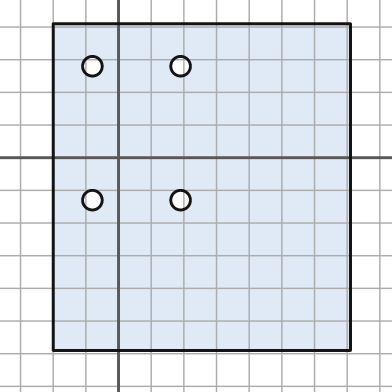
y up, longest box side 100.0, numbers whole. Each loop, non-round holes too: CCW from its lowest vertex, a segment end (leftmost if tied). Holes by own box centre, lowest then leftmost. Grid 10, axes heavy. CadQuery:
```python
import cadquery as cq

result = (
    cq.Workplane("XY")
    .moveTo(-20.0, -59.0)
    .lineTo(71.0, -59.0)
    .lineTo(71.0, 41.0)
    .lineTo(-20.0, 41.0)
    .close()
    .moveTo(-8.0, -13.0)
    .circle(3.0)
    .moveTo(19.0, -13.0)
    .circle(3.0)
    .moveTo(-8.0, 28.0)
    .circle(3.0)
    .moveTo(19.0, 28.0)
    .circle(3.0)
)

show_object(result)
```